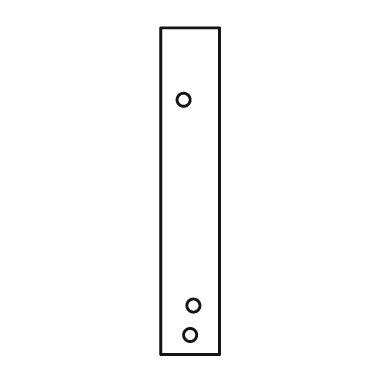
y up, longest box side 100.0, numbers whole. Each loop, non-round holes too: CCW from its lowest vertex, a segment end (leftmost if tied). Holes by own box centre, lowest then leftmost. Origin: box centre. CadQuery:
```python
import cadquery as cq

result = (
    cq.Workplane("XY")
    .moveTo(-9.0, -50.0)
    .lineTo(9.0, -50.0)
    .lineTo(9.0, 50.0)
    .lineTo(-9.0, 50.0)
    .close()
    .moveTo(0.0, -44.0)
    .circle(2.0)
    .moveTo(1.0, -35.0)
    .circle(2.0)
    .moveTo(-2.0, 28.0)
    .circle(2.0)
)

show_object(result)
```